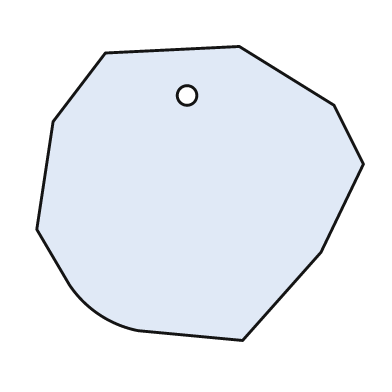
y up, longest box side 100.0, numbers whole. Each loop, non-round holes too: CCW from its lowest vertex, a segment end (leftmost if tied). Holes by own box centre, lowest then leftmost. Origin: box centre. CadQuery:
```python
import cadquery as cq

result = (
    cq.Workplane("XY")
    .moveTo(13.0, -45.0)
    .lineTo(37.0, -18.0)
    .lineTo(50.0, 9.0)
    .lineTo(41.0, 27.0)
    .lineTo(12.0, 45.0)
    .lineTo(-29.0, 43.0)
    .lineTo(-45.0, 22.0)
    .lineTo(-50.0, -11.0)
    .lineTo(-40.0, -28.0)
    .threePointArc((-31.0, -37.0), (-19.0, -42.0))
    .close()
    .moveTo(-4.0, 30.0)
    .circle(3.0)
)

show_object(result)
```